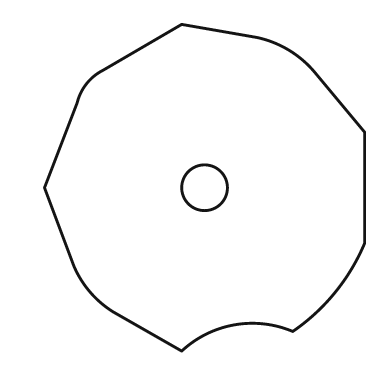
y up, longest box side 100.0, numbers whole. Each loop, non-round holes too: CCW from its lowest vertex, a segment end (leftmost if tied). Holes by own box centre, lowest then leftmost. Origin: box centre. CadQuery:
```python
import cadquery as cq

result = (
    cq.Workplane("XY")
    .moveTo(-7.0, -50.0)
    .threePointArc((9.0, -42.0), (27.0, -44.0))
    .threePointArc((40.0, -32.0), (49.0, -17.0))
    .lineTo(49.0, 17.0)
    .lineTo(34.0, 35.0)
    .threePointArc((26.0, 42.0), (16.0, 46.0))
    .lineTo(-7.0, 50.0)
    .lineTo(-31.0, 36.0)
    .threePointArc((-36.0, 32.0), (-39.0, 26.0))
    .lineTo(-49.0, 0.0)
    .lineTo(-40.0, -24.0)
    .threePointArc((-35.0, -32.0), (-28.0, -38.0))
    .close()
    .moveTo(0.0, 0.0)
    .circle(7.0)
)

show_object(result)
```